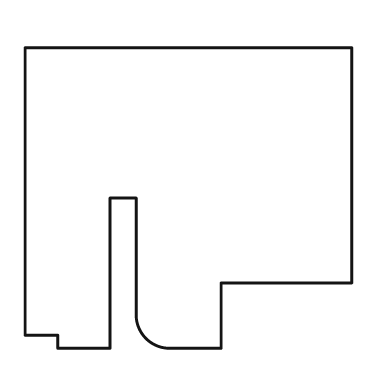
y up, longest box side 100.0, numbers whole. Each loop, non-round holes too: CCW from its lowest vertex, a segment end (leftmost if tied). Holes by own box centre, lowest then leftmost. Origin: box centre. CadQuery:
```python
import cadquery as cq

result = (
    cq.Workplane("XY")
    .moveTo(-40.0, -46.0)
    .lineTo(-24.0, -46.0)
    .lineTo(-24.0, 0.0)
    .lineTo(-16.0, 0.0)
    .lineTo(-16.0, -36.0)
    .threePointArc((-13.0, -43.0), (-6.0, -46.0))
    .lineTo(10.0, -46.0)
    .lineTo(10.0, -26.0)
    .lineTo(50.0, -26.0)
    .lineTo(50.0, 46.0)
    .lineTo(-50.0, 46.0)
    .lineTo(-50.0, -42.0)
    .lineTo(-40.0, -42.0)
    .close()
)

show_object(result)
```